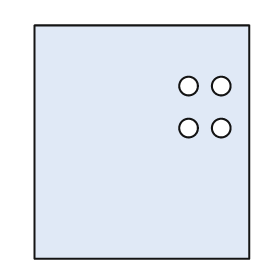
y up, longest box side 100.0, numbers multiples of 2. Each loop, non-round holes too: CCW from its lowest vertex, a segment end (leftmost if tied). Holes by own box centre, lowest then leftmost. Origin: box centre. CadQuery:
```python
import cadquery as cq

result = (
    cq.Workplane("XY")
    .moveTo(-46.0, -50.0)
    .lineTo(46.0, -50.0)
    .lineTo(46.0, 50.0)
    .lineTo(-46.0, 50.0)
    .close()
    .moveTo(20.0, 6.0)
    .circle(4.0)
    .moveTo(34.0, 6.0)
    .circle(4.0)
    .moveTo(20.0, 24.0)
    .circle(4.0)
    .moveTo(34.0, 24.0)
    .circle(4.0)
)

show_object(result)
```